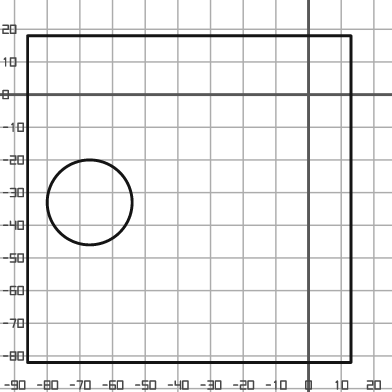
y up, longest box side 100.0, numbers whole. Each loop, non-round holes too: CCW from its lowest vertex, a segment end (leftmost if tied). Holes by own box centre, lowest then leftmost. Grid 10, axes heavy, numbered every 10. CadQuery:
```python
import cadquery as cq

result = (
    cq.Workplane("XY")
    .moveTo(-86.0, -82.0)
    .lineTo(13.0, -82.0)
    .lineTo(13.0, 18.0)
    .lineTo(-86.0, 18.0)
    .close()
    .moveTo(-67.0, -33.0)
    .circle(13.0)
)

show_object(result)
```